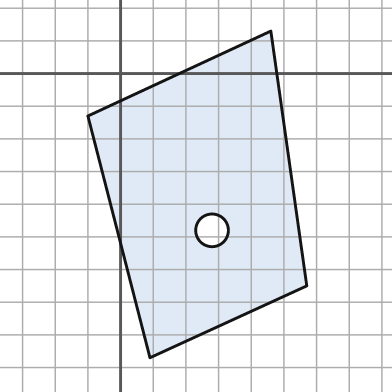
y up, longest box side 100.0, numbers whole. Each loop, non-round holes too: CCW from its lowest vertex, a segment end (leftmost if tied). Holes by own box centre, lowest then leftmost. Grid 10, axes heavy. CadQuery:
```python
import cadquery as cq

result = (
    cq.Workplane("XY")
    .moveTo(9.0, -87.0)
    .lineTo(57.0, -65.0)
    .lineTo(46.0, 13.0)
    .lineTo(-10.0, -13.0)
    .close()
    .moveTo(28.0, -48.0)
    .circle(5.0)
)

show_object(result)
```